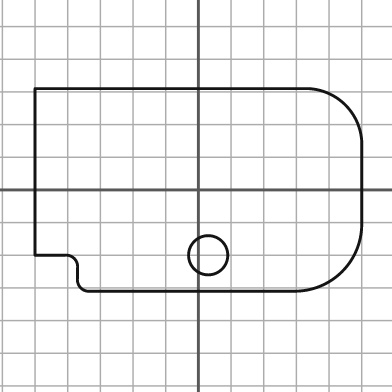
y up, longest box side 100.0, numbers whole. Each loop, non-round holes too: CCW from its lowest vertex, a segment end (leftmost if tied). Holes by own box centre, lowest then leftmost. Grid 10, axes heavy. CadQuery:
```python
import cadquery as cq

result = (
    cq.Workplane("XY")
    .moveTo(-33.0, -31.0)
    .lineTo(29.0, -31.0)
    .threePointArc((44.0, -25.0), (50.0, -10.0))
    .lineTo(50.0, 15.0)
    .threePointArc((45.0, 26.0), (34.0, 31.0))
    .lineTo(-50.0, 31.0)
    .lineTo(-50.0, -20.0)
    .lineTo(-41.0, -20.0)
    .threePointArc((-38.0, -21.0), (-37.0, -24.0))
    .lineTo(-37.0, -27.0)
    .threePointArc((-36.0, -30.0), (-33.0, -31.0))
    .close()
    .moveTo(3.0, -20.0)
    .circle(6.0)
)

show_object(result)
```